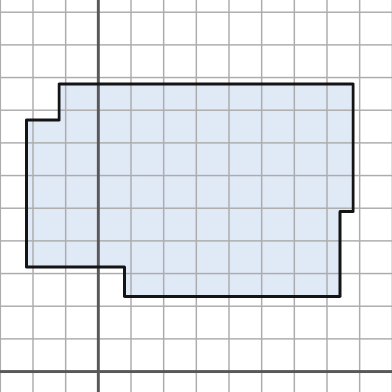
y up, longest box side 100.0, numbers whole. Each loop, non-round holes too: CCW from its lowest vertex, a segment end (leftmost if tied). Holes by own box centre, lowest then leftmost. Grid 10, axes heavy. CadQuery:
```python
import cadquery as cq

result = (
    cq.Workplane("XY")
    .moveTo(8.0, 23.0)
    .lineTo(74.0, 23.0)
    .lineTo(74.0, 49.0)
    .lineTo(78.0, 49.0)
    .lineTo(78.0, 88.0)
    .lineTo(-12.0, 88.0)
    .lineTo(-12.0, 77.0)
    .lineTo(-22.0, 77.0)
    .lineTo(-22.0, 32.0)
    .lineTo(8.0, 32.0)
    .close()
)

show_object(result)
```